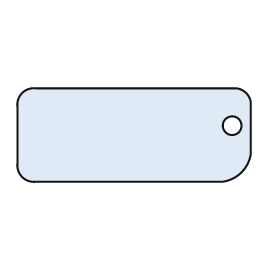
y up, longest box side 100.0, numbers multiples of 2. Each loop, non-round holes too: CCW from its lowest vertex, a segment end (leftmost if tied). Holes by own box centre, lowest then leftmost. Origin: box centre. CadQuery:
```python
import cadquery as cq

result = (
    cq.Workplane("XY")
    .moveTo(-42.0, -20.0)
    .lineTo(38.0, -20.0)
    .threePointArc((46.0, -16.0), (50.0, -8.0))
    .lineTo(50.0, 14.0)
    .threePointArc((48.0, 18.0), (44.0, 20.0))
    .lineTo(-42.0, 20.0)
    .threePointArc((-48.0, 18.0), (-50.0, 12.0))
    .lineTo(-50.0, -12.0)
    .threePointArc((-48.0, -18.0), (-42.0, -20.0))
    .close()
    .moveTo(42.0, 4.0)
    .circle(4.0)
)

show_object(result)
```